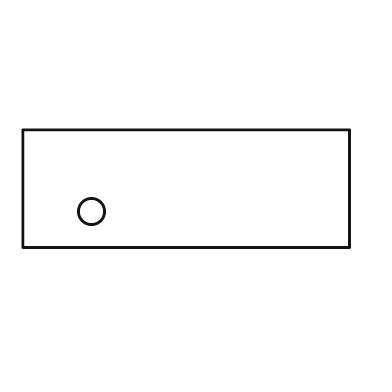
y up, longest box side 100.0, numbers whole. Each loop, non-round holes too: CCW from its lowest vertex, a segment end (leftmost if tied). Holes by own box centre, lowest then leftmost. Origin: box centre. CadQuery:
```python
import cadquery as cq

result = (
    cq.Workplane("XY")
    .moveTo(-50.0, -18.0)
    .lineTo(50.0, -18.0)
    .lineTo(50.0, 18.0)
    .lineTo(-50.0, 18.0)
    .close()
    .moveTo(-29.0, -7.0)
    .circle(4.0)
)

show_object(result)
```